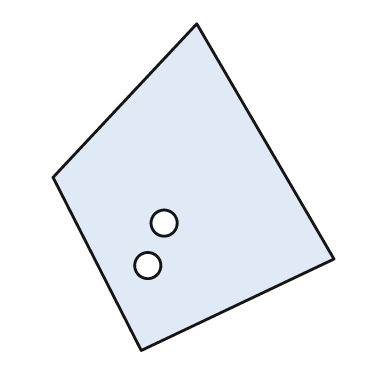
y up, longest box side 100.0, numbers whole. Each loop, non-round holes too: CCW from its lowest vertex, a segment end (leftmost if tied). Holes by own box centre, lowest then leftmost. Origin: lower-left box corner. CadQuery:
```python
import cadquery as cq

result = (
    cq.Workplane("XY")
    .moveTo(27.0, 0.0)
    .lineTo(86.0, 28.0)
    .lineTo(44.0, 100.0)
    .lineTo(0.0, 53.0)
    .close()
    .moveTo(29.0, 26.0)
    .circle(4.0)
    .moveTo(34.0, 39.0)
    .circle(4.0)
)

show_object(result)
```